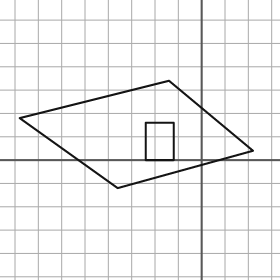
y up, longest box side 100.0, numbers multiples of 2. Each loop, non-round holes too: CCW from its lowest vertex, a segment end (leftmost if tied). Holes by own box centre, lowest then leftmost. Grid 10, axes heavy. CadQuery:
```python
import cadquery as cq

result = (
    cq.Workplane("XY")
    .moveTo(-36.0, -12.0)
    .lineTo(22.0, 4.0)
    .lineTo(-14.0, 34.0)
    .lineTo(-78.0, 18.0)
    .close()
    .moveTo(-24.0, 0.0)
    .lineTo(-12.0, 0.0)
    .lineTo(-12.0, 16.0)
    .lineTo(-24.0, 16.0)
    .close()
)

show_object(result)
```